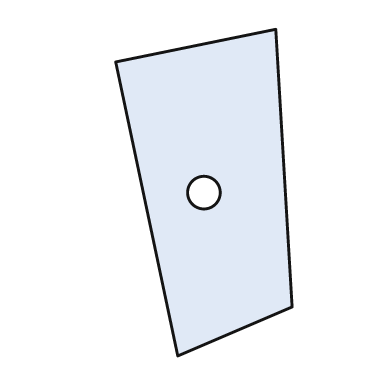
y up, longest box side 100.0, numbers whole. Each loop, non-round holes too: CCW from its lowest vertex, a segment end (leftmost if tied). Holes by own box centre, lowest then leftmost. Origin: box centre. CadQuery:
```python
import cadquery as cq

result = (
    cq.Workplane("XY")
    .moveTo(-8.0, -50.0)
    .lineTo(27.0, -35.0)
    .lineTo(22.0, 50.0)
    .lineTo(-27.0, 40.0)
    .close()
    .moveTo(0.0, 0.0)
    .circle(5.0)
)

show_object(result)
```